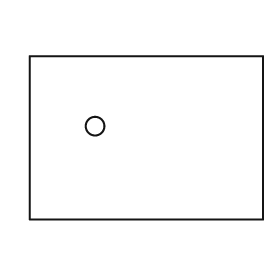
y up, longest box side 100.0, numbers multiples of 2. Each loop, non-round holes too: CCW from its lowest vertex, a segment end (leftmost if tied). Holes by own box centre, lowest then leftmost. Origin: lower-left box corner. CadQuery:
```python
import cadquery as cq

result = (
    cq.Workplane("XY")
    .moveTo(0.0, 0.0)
    .lineTo(100.0, 0.0)
    .lineTo(100.0, 70.0)
    .lineTo(0.0, 70.0)
    .close()
    .moveTo(28.0, 40.0)
    .circle(4.0)
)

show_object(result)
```